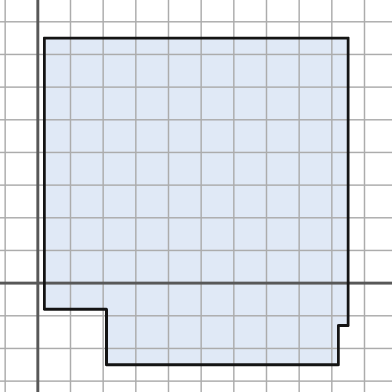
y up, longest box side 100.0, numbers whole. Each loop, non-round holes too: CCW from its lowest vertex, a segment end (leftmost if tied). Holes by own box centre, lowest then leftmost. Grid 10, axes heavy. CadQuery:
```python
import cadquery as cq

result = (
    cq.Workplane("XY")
    .moveTo(21.0, -25.0)
    .lineTo(92.0, -25.0)
    .lineTo(92.0, -13.0)
    .lineTo(95.0, -13.0)
    .lineTo(95.0, 75.0)
    .lineTo(2.0, 75.0)
    .lineTo(2.0, -8.0)
    .lineTo(21.0, -8.0)
    .close()
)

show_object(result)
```